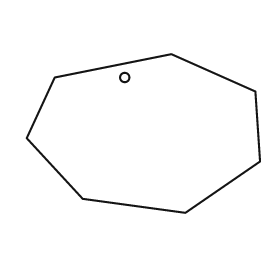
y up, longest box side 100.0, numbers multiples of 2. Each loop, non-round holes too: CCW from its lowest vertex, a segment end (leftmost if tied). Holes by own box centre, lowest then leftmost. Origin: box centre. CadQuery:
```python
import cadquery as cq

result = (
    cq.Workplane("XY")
    .moveTo(18.0, -34.0)
    .lineTo(50.0, -12.0)
    .lineTo(48.0, 18.0)
    .lineTo(12.0, 34.0)
    .lineTo(-38.0, 24.0)
    .lineTo(-50.0, -2.0)
    .lineTo(-26.0, -28.0)
    .close()
    .moveTo(-8.0, 24.0)
    .circle(2.0)
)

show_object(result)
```